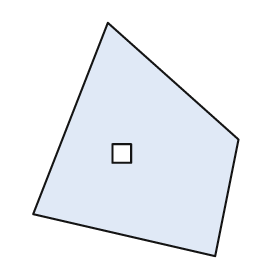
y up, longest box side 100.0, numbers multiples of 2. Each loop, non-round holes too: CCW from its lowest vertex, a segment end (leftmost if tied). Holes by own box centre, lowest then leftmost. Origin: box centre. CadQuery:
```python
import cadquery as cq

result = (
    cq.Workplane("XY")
    .moveTo(34.0, -50.0)
    .lineTo(44.0, 0.0)
    .lineTo(-12.0, 50.0)
    .lineTo(-44.0, -32.0)
    .close()
    .moveTo(-10.0, -10.0)
    .lineTo(-2.0, -10.0)
    .lineTo(-2.0, -2.0)
    .lineTo(-10.0, -2.0)
    .close()
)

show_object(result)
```